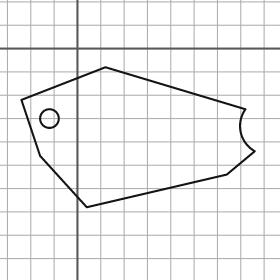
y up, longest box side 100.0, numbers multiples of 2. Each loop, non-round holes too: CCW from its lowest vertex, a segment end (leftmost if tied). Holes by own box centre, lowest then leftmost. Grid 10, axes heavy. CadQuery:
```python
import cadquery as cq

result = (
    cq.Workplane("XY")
    .moveTo(4.0, -68.0)
    .lineTo(64.0, -54.0)
    .lineTo(76.0, -44.0)
    .threePointArc((70.0, -36.0), (72.0, -26.0))
    .lineTo(12.0, -8.0)
    .lineTo(-24.0, -22.0)
    .lineTo(-16.0, -46.0)
    .close()
    .moveTo(-12.0, -30.0)
    .circle(4.0)
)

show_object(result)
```